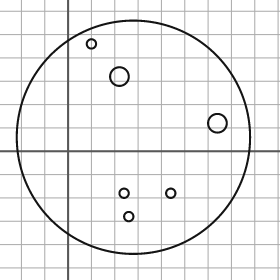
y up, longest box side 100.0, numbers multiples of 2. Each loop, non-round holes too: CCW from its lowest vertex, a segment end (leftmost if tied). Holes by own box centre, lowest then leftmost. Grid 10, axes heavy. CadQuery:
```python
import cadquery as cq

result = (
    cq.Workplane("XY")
    .moveTo(28.0, 6.0)
    .circle(50.0)
    .moveTo(26.0, -28.0)
    .circle(2.0)
    .moveTo(24.0, -18.0)
    .circle(2.0)
    .moveTo(44.0, -18.0)
    .circle(2.0)
    .moveTo(64.0, 12.0)
    .circle(4.0)
    .moveTo(22.0, 32.0)
    .circle(4.0)
    .moveTo(10.0, 46.0)
    .circle(2.0)
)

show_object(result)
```